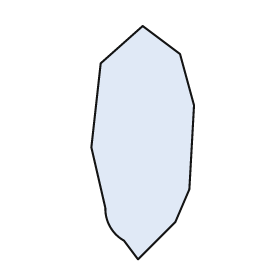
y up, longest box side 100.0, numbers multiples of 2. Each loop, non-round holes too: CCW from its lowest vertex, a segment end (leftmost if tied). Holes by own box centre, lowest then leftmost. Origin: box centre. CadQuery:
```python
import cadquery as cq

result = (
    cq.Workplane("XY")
    .moveTo(-2.0, -50.0)
    .lineTo(14.0, -34.0)
    .lineTo(20.0, -20.0)
    .lineTo(22.0, 16.0)
    .lineTo(16.0, 38.0)
    .lineTo(0.0, 50.0)
    .lineTo(-18.0, 34.0)
    .lineTo(-22.0, -2.0)
    .lineTo(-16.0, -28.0)
    .threePointArc((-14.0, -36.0), (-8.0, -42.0))
    .close()
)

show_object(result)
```